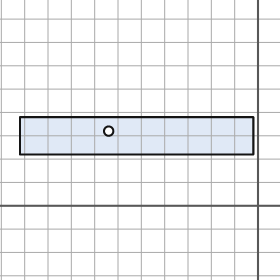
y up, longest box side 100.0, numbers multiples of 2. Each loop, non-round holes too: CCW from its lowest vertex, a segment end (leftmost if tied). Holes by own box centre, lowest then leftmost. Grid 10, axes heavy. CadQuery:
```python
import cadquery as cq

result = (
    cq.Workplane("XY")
    .moveTo(-102.0, 22.0)
    .lineTo(-2.0, 22.0)
    .lineTo(-2.0, 38.0)
    .lineTo(-102.0, 38.0)
    .close()
    .moveTo(-64.0, 32.0)
    .circle(2.0)
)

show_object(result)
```